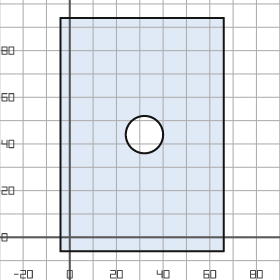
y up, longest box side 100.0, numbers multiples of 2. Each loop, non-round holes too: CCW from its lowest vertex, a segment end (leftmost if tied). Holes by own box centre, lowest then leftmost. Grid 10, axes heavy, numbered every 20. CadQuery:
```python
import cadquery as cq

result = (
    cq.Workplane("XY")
    .moveTo(-4.0, -6.0)
    .lineTo(66.0, -6.0)
    .lineTo(66.0, 94.0)
    .lineTo(-4.0, 94.0)
    .close()
    .moveTo(32.0, 44.0)
    .circle(8.0)
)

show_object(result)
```